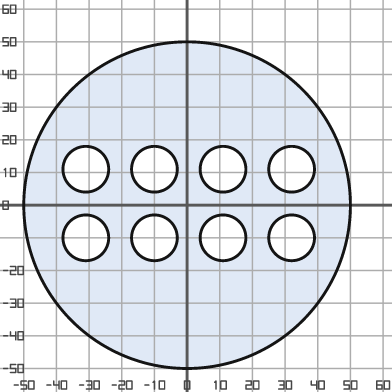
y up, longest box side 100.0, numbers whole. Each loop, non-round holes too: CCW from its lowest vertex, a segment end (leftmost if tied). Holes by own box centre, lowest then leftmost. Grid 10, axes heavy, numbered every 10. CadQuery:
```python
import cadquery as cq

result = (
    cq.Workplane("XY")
    .moveTo(0.0, 0.0)
    .circle(50.0)
    .moveTo(-31.0, -10.0)
    .circle(7.0)
    .moveTo(-10.0, -10.0)
    .circle(7.0)
    .moveTo(11.0, -10.0)
    .circle(7.0)
    .moveTo(32.0, -10.0)
    .circle(7.0)
    .moveTo(-31.0, 11.0)
    .circle(7.0)
    .moveTo(-10.0, 11.0)
    .circle(7.0)
    .moveTo(11.0, 11.0)
    .circle(7.0)
    .moveTo(32.0, 11.0)
    .circle(7.0)
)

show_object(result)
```